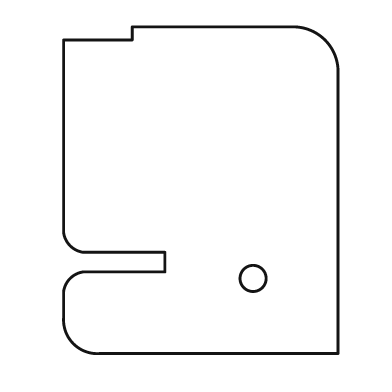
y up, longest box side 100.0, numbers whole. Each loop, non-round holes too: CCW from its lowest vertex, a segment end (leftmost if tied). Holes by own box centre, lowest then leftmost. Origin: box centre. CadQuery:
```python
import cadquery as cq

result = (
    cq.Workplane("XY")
    .moveTo(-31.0, -50.0)
    .lineTo(42.0, -50.0)
    .lineTo(42.0, 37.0)
    .threePointArc((38.0, 46.0), (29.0, 50.0))
    .lineTo(-21.0, 50.0)
    .lineTo(-21.0, 46.0)
    .lineTo(-42.0, 46.0)
    .lineTo(-42.0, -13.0)
    .threePointArc((-40.0, -17.0), (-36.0, -19.0))
    .lineTo(-11.0, -19.0)
    .lineTo(-11.0, -25.0)
    .lineTo(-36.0, -25.0)
    .threePointArc((-40.0, -27.0), (-42.0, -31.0))
    .lineTo(-42.0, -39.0)
    .threePointArc((-39.0, -47.0), (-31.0, -50.0))
    .close()
    .moveTo(16.0, -27.0)
    .circle(4.0)
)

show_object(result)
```